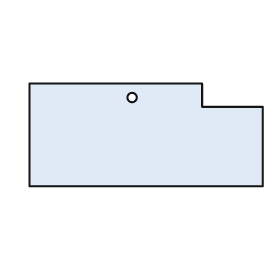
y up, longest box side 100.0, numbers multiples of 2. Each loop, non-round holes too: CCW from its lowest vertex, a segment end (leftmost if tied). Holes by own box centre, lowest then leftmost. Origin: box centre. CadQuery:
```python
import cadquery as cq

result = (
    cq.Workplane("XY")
    .moveTo(-50.0, -22.0)
    .lineTo(50.0, -22.0)
    .lineTo(50.0, 12.0)
    .lineTo(24.0, 12.0)
    .lineTo(24.0, 22.0)
    .lineTo(-50.0, 22.0)
    .close()
    .moveTo(-6.0, 16.0)
    .circle(2.0)
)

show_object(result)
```